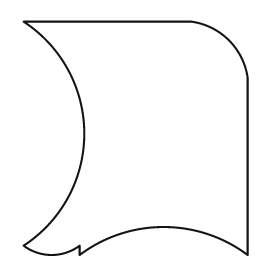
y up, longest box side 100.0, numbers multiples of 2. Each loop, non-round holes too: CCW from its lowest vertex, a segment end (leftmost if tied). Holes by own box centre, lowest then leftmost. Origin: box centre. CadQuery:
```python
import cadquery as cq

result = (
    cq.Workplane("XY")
    .moveTo(-24.0, -50.0)
    .threePointArc((12.0, -38.0), (48.0, -50.0))
    .lineTo(48.0, 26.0)
    .threePointArc((40.0, 42.0), (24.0, 50.0))
    .lineTo(-48.0, 50.0)
    .threePointArc((-22.0, 2.0), (-48.0, -46.0))
    .threePointArc((-36.0, -50.0), (-24.0, -46.0))
    .close()
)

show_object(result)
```